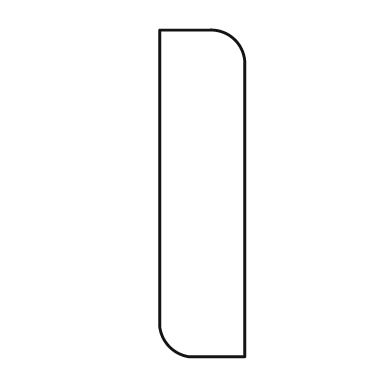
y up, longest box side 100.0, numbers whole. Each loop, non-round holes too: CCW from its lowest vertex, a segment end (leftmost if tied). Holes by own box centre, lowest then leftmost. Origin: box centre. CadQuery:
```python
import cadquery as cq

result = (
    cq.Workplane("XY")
    .moveTo(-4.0, -50.0)
    .lineTo(13.0, -50.0)
    .lineTo(13.0, 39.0)
    .threePointArc((10.0, 47.0), (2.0, 50.0))
    .lineTo(-13.0, 50.0)
    .lineTo(-13.0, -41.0)
    .threePointArc((-10.0, -47.0), (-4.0, -50.0))
    .close()
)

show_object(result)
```